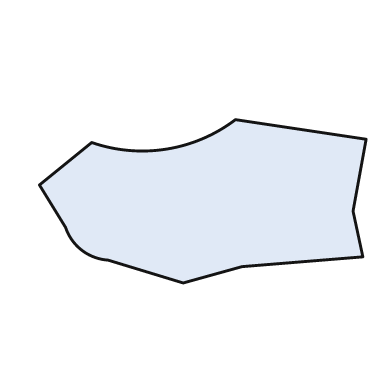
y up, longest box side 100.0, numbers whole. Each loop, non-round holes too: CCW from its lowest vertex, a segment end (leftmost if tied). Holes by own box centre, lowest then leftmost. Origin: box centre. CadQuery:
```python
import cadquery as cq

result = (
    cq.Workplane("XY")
    .moveTo(-6.0, -25.0)
    .lineTo(12.0, -20.0)
    .lineTo(49.0, -17.0)
    .lineTo(46.0, -3.0)
    .lineTo(50.0, 19.0)
    .lineTo(10.0, 25.0)
    .threePointArc((-11.0, 16.0), (-34.0, 18.0))
    .lineTo(-50.0, 5.0)
    .lineTo(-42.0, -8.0)
    .threePointArc((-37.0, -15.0), (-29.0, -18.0))
    .close()
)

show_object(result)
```